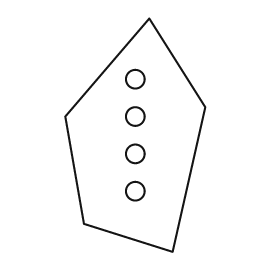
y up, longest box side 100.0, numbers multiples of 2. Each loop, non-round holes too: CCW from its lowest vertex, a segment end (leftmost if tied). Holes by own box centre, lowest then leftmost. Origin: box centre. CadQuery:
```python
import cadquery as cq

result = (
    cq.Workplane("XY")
    .moveTo(16.0, -50.0)
    .lineTo(30.0, 12.0)
    .lineTo(6.0, 50.0)
    .lineTo(-30.0, 8.0)
    .lineTo(-22.0, -38.0)
    .close()
    .moveTo(0.0, -24.0)
    .circle(4.0)
    .moveTo(0.0, -8.0)
    .circle(4.0)
    .moveTo(0.0, 8.0)
    .circle(4.0)
    .moveTo(0.0, 24.0)
    .circle(4.0)
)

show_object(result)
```